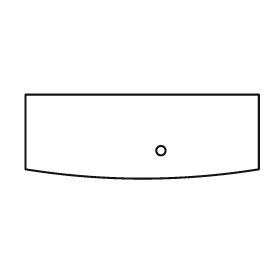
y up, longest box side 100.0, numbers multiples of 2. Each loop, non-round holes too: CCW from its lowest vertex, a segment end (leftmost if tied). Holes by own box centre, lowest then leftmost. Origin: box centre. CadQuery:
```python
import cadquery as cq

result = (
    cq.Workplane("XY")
    .moveTo(-50.0, -14.0)
    .threePointArc((0.0, -18.0), (50.0, -14.0))
    .lineTo(50.0, 18.0)
    .lineTo(-50.0, 18.0)
    .close()
    .moveTo(8.0, -6.0)
    .circle(2.0)
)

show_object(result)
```